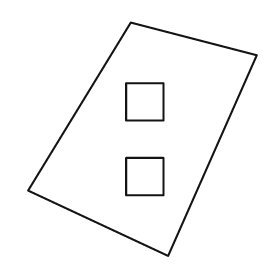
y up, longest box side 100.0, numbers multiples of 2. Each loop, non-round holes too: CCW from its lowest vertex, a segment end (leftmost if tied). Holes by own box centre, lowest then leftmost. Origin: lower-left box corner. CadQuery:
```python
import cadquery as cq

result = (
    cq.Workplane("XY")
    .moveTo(60.0, 0.0)
    .lineTo(98.0, 86.0)
    .lineTo(44.0, 100.0)
    .lineTo(0.0, 28.0)
    .close()
    .moveTo(42.0, 26.0)
    .lineTo(58.0, 26.0)
    .lineTo(58.0, 42.0)
    .lineTo(42.0, 42.0)
    .close()
    .moveTo(42.0, 58.0)
    .lineTo(58.0, 58.0)
    .lineTo(58.0, 74.0)
    .lineTo(42.0, 74.0)
    .close()
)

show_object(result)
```